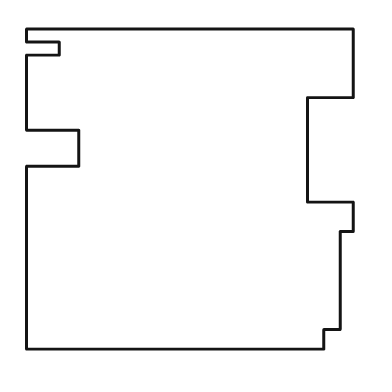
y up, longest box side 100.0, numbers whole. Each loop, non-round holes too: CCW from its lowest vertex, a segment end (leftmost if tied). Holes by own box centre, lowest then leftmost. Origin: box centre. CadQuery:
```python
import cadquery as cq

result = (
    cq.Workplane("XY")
    .moveTo(-50.0, -49.0)
    .lineTo(41.0, -49.0)
    .lineTo(41.0, -43.0)
    .lineTo(46.0, -43.0)
    .lineTo(46.0, -13.0)
    .lineTo(50.0, -13.0)
    .lineTo(50.0, -4.0)
    .lineTo(36.0, -4.0)
    .lineTo(36.0, 28.0)
    .lineTo(50.0, 28.0)
    .lineTo(50.0, 49.0)
    .lineTo(-50.0, 49.0)
    .lineTo(-50.0, 45.0)
    .lineTo(-40.0, 45.0)
    .lineTo(-40.0, 41.0)
    .lineTo(-50.0, 41.0)
    .lineTo(-50.0, 18.0)
    .lineTo(-34.0, 18.0)
    .lineTo(-34.0, 7.0)
    .lineTo(-50.0, 7.0)
    .close()
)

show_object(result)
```